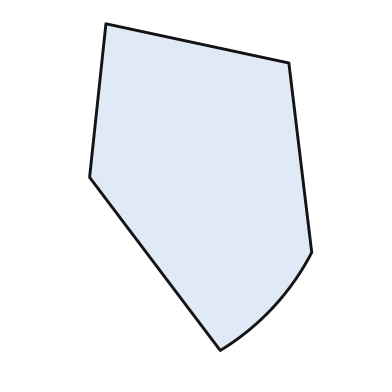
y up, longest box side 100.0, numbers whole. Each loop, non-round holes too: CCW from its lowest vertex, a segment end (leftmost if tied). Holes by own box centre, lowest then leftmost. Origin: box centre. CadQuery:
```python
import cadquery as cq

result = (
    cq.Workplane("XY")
    .moveTo(6.0, -50.0)
    .threePointArc((22.0, -37.0), (34.0, -20.0))
    .lineTo(27.0, 38.0)
    .lineTo(-29.0, 50.0)
    .lineTo(-34.0, 3.0)
    .close()
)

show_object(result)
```